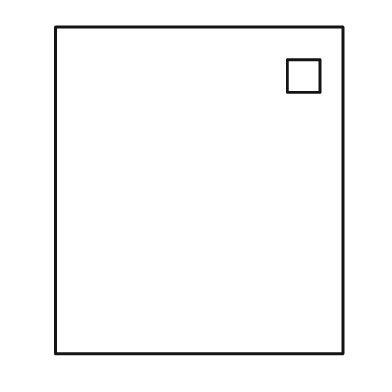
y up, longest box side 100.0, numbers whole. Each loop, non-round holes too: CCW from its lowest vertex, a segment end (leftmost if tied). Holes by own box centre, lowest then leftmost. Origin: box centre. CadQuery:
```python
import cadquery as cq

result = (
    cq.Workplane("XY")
    .moveTo(-44.0, -50.0)
    .lineTo(44.0, -50.0)
    .lineTo(44.0, 50.0)
    .lineTo(-44.0, 50.0)
    .close()
    .moveTo(27.0, 30.0)
    .lineTo(37.0, 30.0)
    .lineTo(37.0, 40.0)
    .lineTo(27.0, 40.0)
    .close()
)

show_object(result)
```